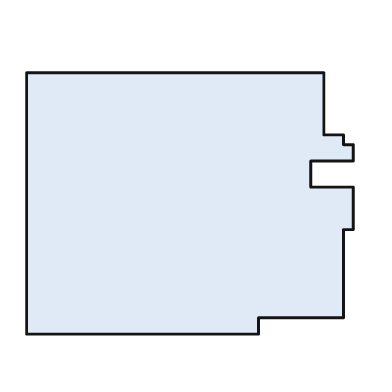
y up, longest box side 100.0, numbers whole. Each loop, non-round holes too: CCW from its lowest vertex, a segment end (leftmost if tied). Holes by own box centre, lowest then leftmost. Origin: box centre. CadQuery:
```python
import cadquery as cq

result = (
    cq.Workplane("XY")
    .moveTo(-50.0, -40.0)
    .lineTo(21.0, -40.0)
    .lineTo(21.0, -35.0)
    .lineTo(47.0, -35.0)
    .lineTo(47.0, -8.0)
    .lineTo(50.0, -8.0)
    .lineTo(50.0, 5.0)
    .lineTo(37.0, 5.0)
    .lineTo(37.0, 13.0)
    .lineTo(50.0, 13.0)
    .lineTo(50.0, 18.0)
    .lineTo(47.0, 18.0)
    .lineTo(47.0, 21.0)
    .lineTo(41.0, 21.0)
    .lineTo(41.0, 40.0)
    .lineTo(-50.0, 40.0)
    .close()
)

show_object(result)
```